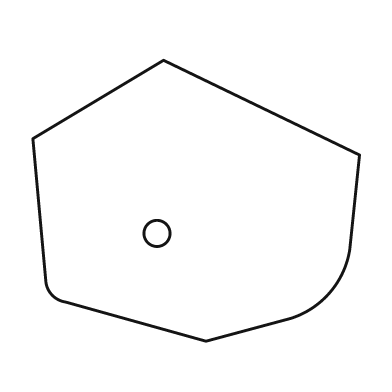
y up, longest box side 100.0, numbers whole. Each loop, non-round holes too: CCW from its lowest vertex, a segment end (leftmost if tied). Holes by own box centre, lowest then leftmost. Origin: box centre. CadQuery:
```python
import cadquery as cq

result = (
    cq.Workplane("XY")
    .moveTo(3.0, -43.0)
    .lineTo(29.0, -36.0)
    .threePointArc((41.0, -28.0), (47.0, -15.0))
    .lineTo(50.0, 14.0)
    .lineTo(-10.0, 43.0)
    .lineTo(-50.0, 19.0)
    .lineTo(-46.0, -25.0)
    .threePointArc((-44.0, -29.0), (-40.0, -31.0))
    .close()
    .moveTo(-12.0, -10.0)
    .circle(4.0)
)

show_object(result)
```